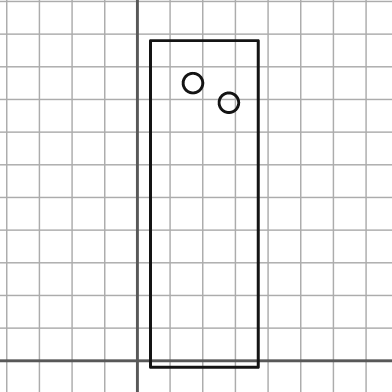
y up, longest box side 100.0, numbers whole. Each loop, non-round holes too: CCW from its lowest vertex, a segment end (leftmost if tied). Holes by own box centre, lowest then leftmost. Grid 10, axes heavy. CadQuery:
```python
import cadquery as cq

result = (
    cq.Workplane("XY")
    .moveTo(4.0, -2.0)
    .lineTo(37.0, -2.0)
    .lineTo(37.0, 98.0)
    .lineTo(4.0, 98.0)
    .close()
    .moveTo(28.0, 79.0)
    .circle(3.0)
    .moveTo(17.0, 85.0)
    .circle(3.0)
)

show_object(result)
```